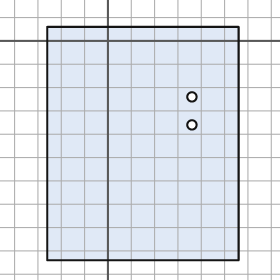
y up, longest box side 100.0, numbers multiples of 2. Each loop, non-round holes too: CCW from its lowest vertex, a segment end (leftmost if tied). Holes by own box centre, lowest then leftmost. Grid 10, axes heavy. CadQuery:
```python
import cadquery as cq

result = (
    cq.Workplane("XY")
    .moveTo(-26.0, -94.0)
    .lineTo(56.0, -94.0)
    .lineTo(56.0, 6.0)
    .lineTo(-26.0, 6.0)
    .close()
    .moveTo(36.0, -36.0)
    .circle(2.0)
    .moveTo(36.0, -24.0)
    .circle(2.0)
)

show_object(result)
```